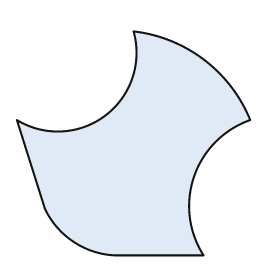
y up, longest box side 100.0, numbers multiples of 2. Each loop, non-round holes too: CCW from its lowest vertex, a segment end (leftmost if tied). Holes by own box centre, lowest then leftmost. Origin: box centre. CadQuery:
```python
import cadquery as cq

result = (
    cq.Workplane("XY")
    .moveTo(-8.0, -48.0)
    .lineTo(30.0, -48.0)
    .threePointArc((26.0, -14.0), (50.0, 10.0))
    .threePointArc((30.0, 36.0), (0.0, 48.0))
    .threePointArc((-12.0, 12.0), (-50.0, 10.0))
    .lineTo(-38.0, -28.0)
    .threePointArc((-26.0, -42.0), (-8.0, -48.0))
    .close()
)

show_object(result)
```